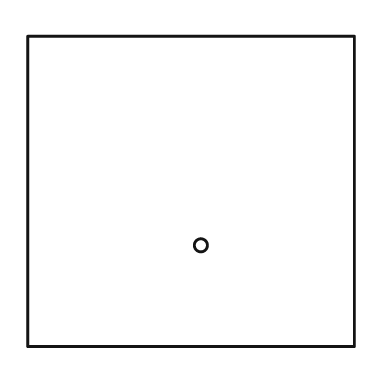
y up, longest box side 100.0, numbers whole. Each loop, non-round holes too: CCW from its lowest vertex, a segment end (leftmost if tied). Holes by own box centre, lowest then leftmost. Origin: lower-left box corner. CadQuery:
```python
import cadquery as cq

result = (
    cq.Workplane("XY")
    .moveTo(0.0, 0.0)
    .lineTo(100.0, 0.0)
    .lineTo(100.0, 95.0)
    .lineTo(0.0, 95.0)
    .close()
    .moveTo(53.0, 31.0)
    .circle(2.0)
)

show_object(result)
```